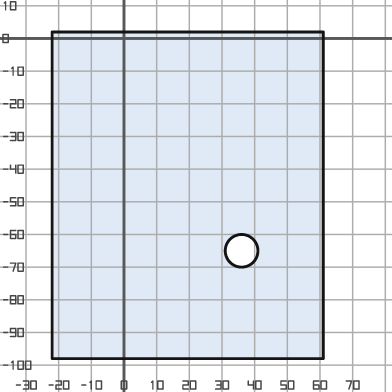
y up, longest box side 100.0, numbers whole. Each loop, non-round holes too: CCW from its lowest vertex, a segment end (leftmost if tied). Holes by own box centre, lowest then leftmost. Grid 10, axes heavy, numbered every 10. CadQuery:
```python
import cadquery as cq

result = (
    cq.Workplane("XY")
    .moveTo(-22.0, -98.0)
    .lineTo(61.0, -98.0)
    .lineTo(61.0, 2.0)
    .lineTo(-22.0, 2.0)
    .close()
    .moveTo(36.0, -65.0)
    .circle(5.0)
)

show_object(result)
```